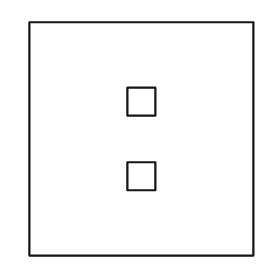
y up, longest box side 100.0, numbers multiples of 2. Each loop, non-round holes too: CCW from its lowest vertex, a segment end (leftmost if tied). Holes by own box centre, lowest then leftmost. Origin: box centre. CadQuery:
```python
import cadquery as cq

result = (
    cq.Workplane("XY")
    .moveTo(-48.0, -50.0)
    .lineTo(48.0, -50.0)
    .lineTo(48.0, 50.0)
    .lineTo(-48.0, 50.0)
    .close()
    .moveTo(-6.0, -22.0)
    .lineTo(6.0, -22.0)
    .lineTo(6.0, -10.0)
    .lineTo(-6.0, -10.0)
    .close()
    .moveTo(-6.0, 10.0)
    .lineTo(6.0, 10.0)
    .lineTo(6.0, 22.0)
    .lineTo(-6.0, 22.0)
    .close()
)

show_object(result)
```